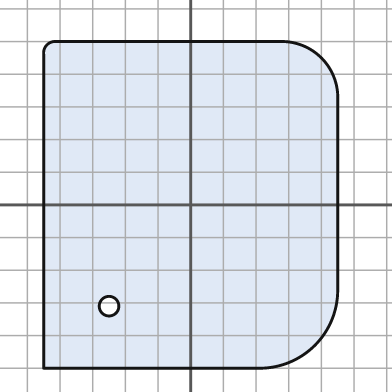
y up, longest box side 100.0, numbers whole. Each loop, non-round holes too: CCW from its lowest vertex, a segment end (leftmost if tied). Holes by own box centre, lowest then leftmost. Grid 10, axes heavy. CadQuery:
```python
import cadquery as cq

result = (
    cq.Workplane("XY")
    .moveTo(-45.0, -50.0)
    .lineTo(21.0, -50.0)
    .threePointArc((38.0, -43.0), (45.0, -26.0))
    .lineTo(45.0, 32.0)
    .threePointArc((40.0, 45.0), (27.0, 50.0))
    .lineTo(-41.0, 50.0)
    .threePointArc((-44.0, 49.0), (-45.0, 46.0))
    .close()
    .moveTo(-25.0, -31.0)
    .circle(3.0)
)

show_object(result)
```